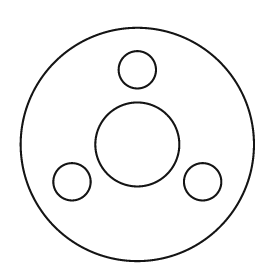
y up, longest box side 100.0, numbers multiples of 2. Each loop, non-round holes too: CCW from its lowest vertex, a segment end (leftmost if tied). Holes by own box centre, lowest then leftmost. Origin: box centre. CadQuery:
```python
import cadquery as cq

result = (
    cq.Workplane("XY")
    .moveTo(0.0, 0.0)
    .circle(50.0)
    .moveTo(-28.0, -16.0)
    .circle(8.0)
    .moveTo(28.0, -16.0)
    .circle(8.0)
    .moveTo(0.0, 0.0)
    .circle(18.0)
    .moveTo(0.0, 32.0)
    .circle(8.0)
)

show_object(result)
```